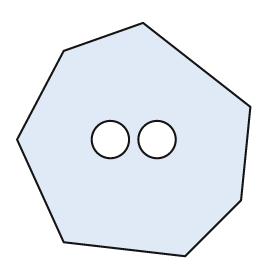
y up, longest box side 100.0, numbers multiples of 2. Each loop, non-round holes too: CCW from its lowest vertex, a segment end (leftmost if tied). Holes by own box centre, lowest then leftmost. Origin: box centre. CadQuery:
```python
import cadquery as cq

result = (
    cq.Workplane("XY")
    .moveTo(22.0, -50.0)
    .lineTo(46.0, -26.0)
    .lineTo(50.0, 14.0)
    .lineTo(4.0, 50.0)
    .lineTo(-30.0, 38.0)
    .lineTo(-50.0, 0.0)
    .lineTo(-30.0, -44.0)
    .close()
    .moveTo(-10.0, 0.0)
    .circle(8.0)
    .moveTo(10.0, 0.0)
    .circle(8.0)
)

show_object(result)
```